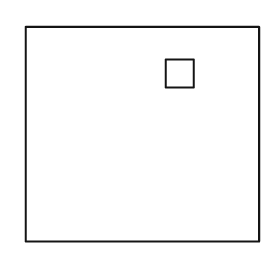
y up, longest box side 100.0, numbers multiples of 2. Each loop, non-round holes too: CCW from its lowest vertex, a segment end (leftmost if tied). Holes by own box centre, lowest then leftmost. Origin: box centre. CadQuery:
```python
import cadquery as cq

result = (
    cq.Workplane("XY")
    .moveTo(-50.0, -46.0)
    .lineTo(50.0, -46.0)
    .lineTo(50.0, 46.0)
    .lineTo(-50.0, 46.0)
    .close()
    .moveTo(10.0, 20.0)
    .lineTo(22.0, 20.0)
    .lineTo(22.0, 32.0)
    .lineTo(10.0, 32.0)
    .close()
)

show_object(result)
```